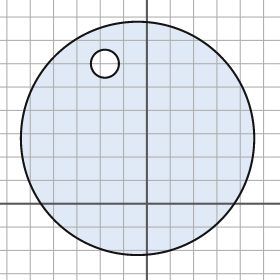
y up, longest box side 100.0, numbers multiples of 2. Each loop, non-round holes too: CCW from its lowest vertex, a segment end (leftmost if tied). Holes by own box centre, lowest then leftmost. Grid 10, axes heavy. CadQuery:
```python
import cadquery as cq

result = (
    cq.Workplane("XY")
    .moveTo(-4.0, 28.0)
    .circle(50.0)
    .moveTo(-18.0, 60.0)
    .circle(6.0)
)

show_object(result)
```